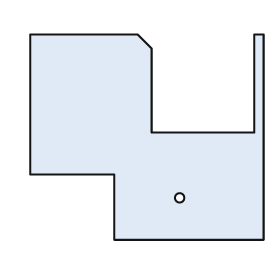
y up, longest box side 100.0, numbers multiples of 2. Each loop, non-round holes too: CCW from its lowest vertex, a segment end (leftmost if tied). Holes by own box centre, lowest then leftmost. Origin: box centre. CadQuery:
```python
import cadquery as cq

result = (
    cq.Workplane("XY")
    .moveTo(-14.0, -44.0)
    .lineTo(50.0, -44.0)
    .lineTo(50.0, 44.0)
    .lineTo(46.0, 44.0)
    .lineTo(46.0, 2.0)
    .lineTo(2.0, 2.0)
    .lineTo(2.0, 38.0)
    .lineTo(-4.0, 44.0)
    .lineTo(-50.0, 44.0)
    .lineTo(-50.0, -16.0)
    .lineTo(-14.0, -16.0)
    .close()
    .moveTo(14.0, -26.0)
    .circle(2.0)
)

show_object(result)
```